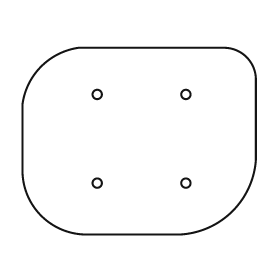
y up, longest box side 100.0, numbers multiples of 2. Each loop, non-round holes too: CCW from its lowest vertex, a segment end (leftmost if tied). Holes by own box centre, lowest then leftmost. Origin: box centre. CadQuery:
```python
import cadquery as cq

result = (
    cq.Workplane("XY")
    .moveTo(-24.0, -40.0)
    .lineTo(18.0, -40.0)
    .threePointArc((40.0, -30.0), (50.0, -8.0))
    .lineTo(50.0, 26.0)
    .threePointArc((46.0, 36.0), (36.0, 40.0))
    .lineTo(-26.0, 40.0)
    .threePointArc((-42.0, 32.0), (-50.0, 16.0))
    .lineTo(-50.0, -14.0)
    .threePointArc((-42.0, -32.0), (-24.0, -40.0))
    .close()
    .moveTo(-18.0, -18.0)
    .circle(2.0)
    .moveTo(20.0, -18.0)
    .circle(2.0)
    .moveTo(-18.0, 20.0)
    .circle(2.0)
    .moveTo(20.0, 20.0)
    .circle(2.0)
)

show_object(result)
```